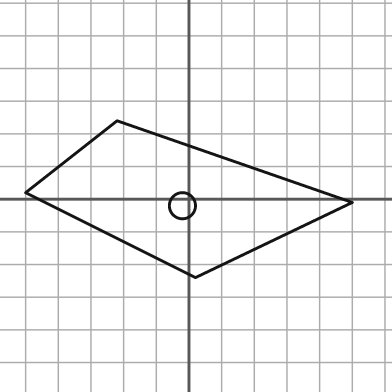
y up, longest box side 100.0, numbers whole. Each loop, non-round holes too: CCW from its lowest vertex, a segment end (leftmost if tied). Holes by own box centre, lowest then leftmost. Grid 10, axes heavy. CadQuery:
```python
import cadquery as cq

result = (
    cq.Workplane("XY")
    .moveTo(2.0, -24.0)
    .lineTo(50.0, -1.0)
    .lineTo(-22.0, 24.0)
    .lineTo(-50.0, 2.0)
    .close()
    .moveTo(-2.0, -2.0)
    .circle(4.0)
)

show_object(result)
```